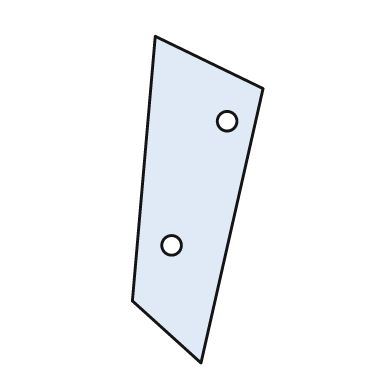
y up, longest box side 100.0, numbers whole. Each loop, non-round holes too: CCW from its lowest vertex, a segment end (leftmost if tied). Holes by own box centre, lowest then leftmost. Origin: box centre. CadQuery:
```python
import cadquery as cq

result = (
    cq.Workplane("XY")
    .moveTo(1.0, -50.0)
    .lineTo(20.0, 34.0)
    .lineTo(-13.0, 50.0)
    .lineTo(-20.0, -31.0)
    .close()
    .moveTo(-8.0, -14.0)
    .circle(3.0)
    .moveTo(9.0, 24.0)
    .circle(3.0)
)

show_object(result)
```